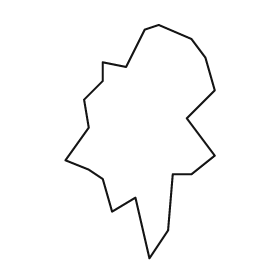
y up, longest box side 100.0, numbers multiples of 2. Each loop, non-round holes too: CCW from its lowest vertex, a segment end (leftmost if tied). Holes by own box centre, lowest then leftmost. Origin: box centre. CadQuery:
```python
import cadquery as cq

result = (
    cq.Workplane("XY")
    .moveTo(4.0, -50.0)
    .lineTo(12.0, -38.0)
    .lineTo(14.0, -14.0)
    .lineTo(22.0, -14.0)
    .lineTo(32.0, -6.0)
    .lineTo(20.0, 10.0)
    .lineTo(32.0, 22.0)
    .lineTo(28.0, 36.0)
    .lineTo(22.0, 44.0)
    .lineTo(8.0, 50.0)
    .lineTo(2.0, 48.0)
    .lineTo(-6.0, 32.0)
    .lineTo(-16.0, 34.0)
    .lineTo(-16.0, 26.0)
    .lineTo(-24.0, 18.0)
    .lineTo(-22.0, 6.0)
    .lineTo(-32.0, -8.0)
    .lineTo(-22.0, -12.0)
    .lineTo(-16.0, -16.0)
    .lineTo(-12.0, -30.0)
    .lineTo(-2.0, -24.0)
    .close()
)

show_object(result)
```